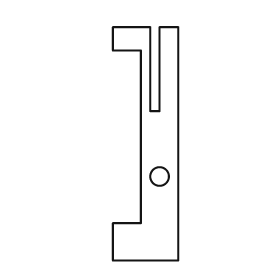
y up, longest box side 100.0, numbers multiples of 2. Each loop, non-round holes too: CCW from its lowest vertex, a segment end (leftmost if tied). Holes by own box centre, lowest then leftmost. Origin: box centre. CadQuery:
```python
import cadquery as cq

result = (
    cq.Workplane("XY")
    .moveTo(-14.0, -50.0)
    .lineTo(14.0, -50.0)
    .lineTo(14.0, 50.0)
    .lineTo(6.0, 50.0)
    .lineTo(6.0, 14.0)
    .lineTo(2.0, 14.0)
    .lineTo(2.0, 50.0)
    .lineTo(-14.0, 50.0)
    .lineTo(-14.0, 40.0)
    .lineTo(-2.0, 40.0)
    .lineTo(-2.0, -34.0)
    .lineTo(-14.0, -34.0)
    .close()
    .moveTo(6.0, -14.0)
    .circle(4.0)
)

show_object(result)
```